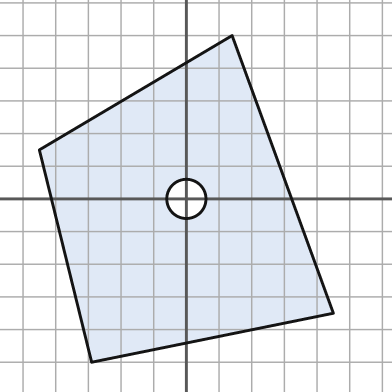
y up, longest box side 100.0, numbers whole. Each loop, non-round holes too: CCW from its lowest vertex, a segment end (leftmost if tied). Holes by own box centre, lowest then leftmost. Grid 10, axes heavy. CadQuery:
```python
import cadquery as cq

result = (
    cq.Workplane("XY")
    .moveTo(-29.0, -50.0)
    .lineTo(45.0, -35.0)
    .lineTo(14.0, 50.0)
    .lineTo(-45.0, 15.0)
    .close()
    .moveTo(0.0, 0.0)
    .circle(6.0)
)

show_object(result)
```